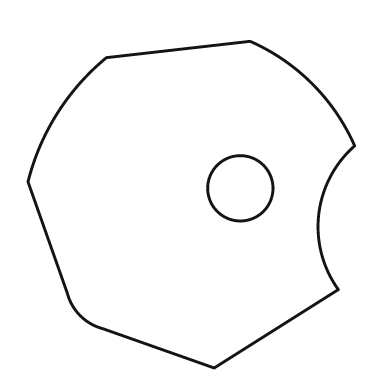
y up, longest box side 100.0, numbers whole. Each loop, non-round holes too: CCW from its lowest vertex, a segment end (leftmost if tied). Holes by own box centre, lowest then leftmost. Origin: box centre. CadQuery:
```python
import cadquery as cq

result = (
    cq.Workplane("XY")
    .moveTo(7.0, -50.0)
    .lineTo(45.0, -26.0)
    .threePointArc((39.0, -3.0), (50.0, 18.0))
    .threePointArc((37.0, 37.0), (18.0, 50.0))
    .lineTo(-26.0, 45.0)
    .threePointArc((-41.0, 28.0), (-50.0, 7.0))
    .lineTo(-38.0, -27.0)
    .threePointArc((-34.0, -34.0), (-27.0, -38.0))
    .close()
    .moveTo(15.0, 5.0)
    .circle(10.0)
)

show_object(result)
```